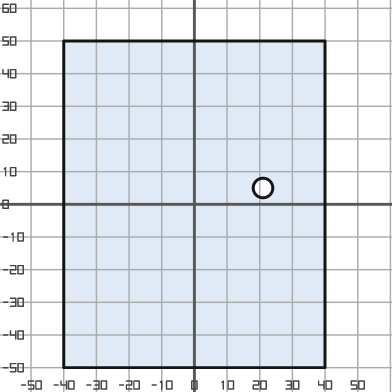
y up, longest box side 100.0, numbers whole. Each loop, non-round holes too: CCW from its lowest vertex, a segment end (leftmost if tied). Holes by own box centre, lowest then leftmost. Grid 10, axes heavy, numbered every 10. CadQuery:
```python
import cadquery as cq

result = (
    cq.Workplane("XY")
    .moveTo(-40.0, -50.0)
    .lineTo(40.0, -50.0)
    .lineTo(40.0, 50.0)
    .lineTo(-40.0, 50.0)
    .close()
    .moveTo(21.0, 5.0)
    .circle(3.0)
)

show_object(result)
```